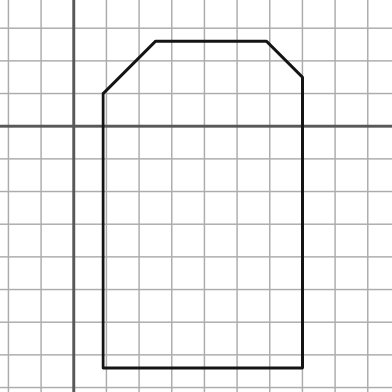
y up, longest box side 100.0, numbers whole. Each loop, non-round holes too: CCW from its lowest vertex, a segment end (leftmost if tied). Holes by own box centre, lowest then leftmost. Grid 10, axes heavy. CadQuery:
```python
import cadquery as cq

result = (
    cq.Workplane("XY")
    .moveTo(9.0, -74.0)
    .lineTo(70.0, -74.0)
    .lineTo(70.0, 15.0)
    .lineTo(59.0, 26.0)
    .lineTo(25.0, 26.0)
    .lineTo(9.0, 10.0)
    .close()
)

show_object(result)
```